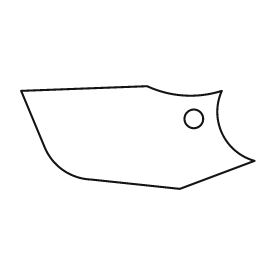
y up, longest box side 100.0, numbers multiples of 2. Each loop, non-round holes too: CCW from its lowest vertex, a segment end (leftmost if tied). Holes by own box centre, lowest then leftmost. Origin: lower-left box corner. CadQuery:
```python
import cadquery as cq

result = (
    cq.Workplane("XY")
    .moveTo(68.0, 0.0)
    .lineTo(100.0, 12.0)
    .threePointArc((86.0, 24.0), (86.0, 42.0))
    .threePointArc((70.0, 40.0), (54.0, 44.0))
    .lineTo(0.0, 42.0)
    .lineTo(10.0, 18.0)
    .threePointArc((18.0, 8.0), (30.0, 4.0))
    .close()
    .moveTo(74.0, 30.0)
    .circle(4.0)
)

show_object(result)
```